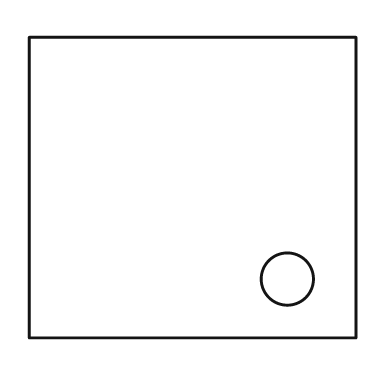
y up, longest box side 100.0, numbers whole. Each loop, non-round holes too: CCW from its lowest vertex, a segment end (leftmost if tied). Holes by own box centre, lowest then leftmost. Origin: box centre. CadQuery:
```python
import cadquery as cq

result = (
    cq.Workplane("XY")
    .moveTo(-50.0, -46.0)
    .lineTo(50.0, -46.0)
    .lineTo(50.0, 46.0)
    .lineTo(-50.0, 46.0)
    .close()
    .moveTo(29.0, -28.0)
    .circle(8.0)
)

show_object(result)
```